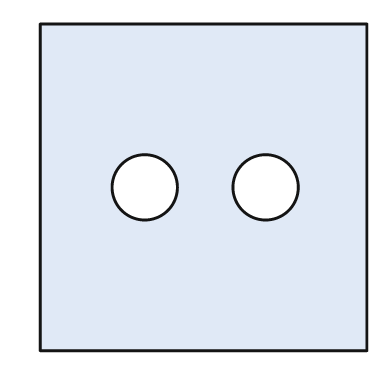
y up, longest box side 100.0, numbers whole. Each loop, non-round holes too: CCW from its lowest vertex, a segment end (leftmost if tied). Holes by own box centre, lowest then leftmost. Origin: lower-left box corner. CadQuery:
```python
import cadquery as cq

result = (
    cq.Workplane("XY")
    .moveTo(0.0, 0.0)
    .lineTo(100.0, 0.0)
    .lineTo(100.0, 100.0)
    .lineTo(0.0, 100.0)
    .close()
    .moveTo(32.0, 50.0)
    .circle(10.0)
    .moveTo(69.0, 50.0)
    .circle(10.0)
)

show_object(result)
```